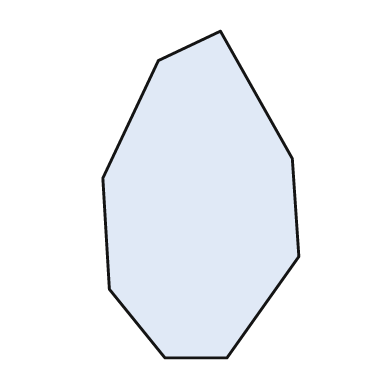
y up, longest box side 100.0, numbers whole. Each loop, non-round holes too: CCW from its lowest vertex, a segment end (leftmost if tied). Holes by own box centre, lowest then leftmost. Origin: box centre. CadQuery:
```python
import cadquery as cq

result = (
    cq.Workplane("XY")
    .moveTo(-11.0, -50.0)
    .lineTo(8.0, -50.0)
    .lineTo(30.0, -19.0)
    .lineTo(28.0, 11.0)
    .lineTo(6.0, 50.0)
    .lineTo(-13.0, 41.0)
    .lineTo(-30.0, 5.0)
    .lineTo(-28.0, -29.0)
    .close()
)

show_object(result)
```